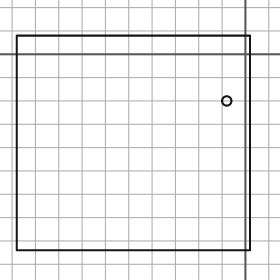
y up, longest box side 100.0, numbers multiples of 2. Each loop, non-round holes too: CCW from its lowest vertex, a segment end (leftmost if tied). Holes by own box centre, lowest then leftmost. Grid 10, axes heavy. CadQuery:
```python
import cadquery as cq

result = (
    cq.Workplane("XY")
    .moveTo(-98.0, -84.0)
    .lineTo(2.0, -84.0)
    .lineTo(2.0, 8.0)
    .lineTo(-98.0, 8.0)
    .close()
    .moveTo(-8.0, -20.0)
    .circle(2.0)
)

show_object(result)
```